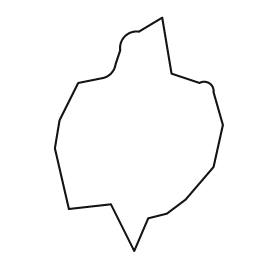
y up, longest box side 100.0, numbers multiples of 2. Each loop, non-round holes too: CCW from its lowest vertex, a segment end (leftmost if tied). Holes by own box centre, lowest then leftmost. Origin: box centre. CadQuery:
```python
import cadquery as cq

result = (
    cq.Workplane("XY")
    .moveTo(-2.0, -50.0)
    .lineTo(4.0, -36.0)
    .lineTo(12.0, -34.0)
    .lineTo(20.0, -28.0)
    .lineTo(32.0, -14.0)
    .lineTo(36.0, 4.0)
    .lineTo(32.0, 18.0)
    .threePointArc((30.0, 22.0), (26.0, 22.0))
    .lineTo(14.0, 26.0)
    .lineTo(10.0, 50.0)
    .lineTo(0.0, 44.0)
    .threePointArc((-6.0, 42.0), (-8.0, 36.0))
    .lineTo(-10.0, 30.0)
    .threePointArc((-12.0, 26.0), (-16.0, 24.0))
    .lineTo(-26.0, 22.0)
    .lineTo(-34.0, 6.0)
    .lineTo(-36.0, -6.0)
    .lineTo(-30.0, -32.0)
    .lineTo(-12.0, -30.0)
    .close()
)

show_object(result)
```